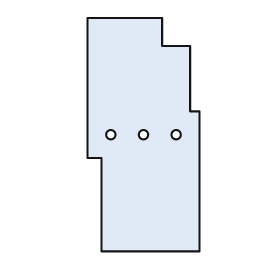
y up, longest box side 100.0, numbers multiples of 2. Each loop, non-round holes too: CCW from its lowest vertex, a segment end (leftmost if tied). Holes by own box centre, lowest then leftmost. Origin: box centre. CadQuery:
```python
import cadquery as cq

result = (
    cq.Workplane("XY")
    .moveTo(-18.0, -50.0)
    .lineTo(24.0, -50.0)
    .lineTo(24.0, 10.0)
    .lineTo(20.0, 10.0)
    .lineTo(20.0, 38.0)
    .lineTo(8.0, 38.0)
    .lineTo(8.0, 50.0)
    .lineTo(-24.0, 50.0)
    .lineTo(-24.0, -10.0)
    .lineTo(-18.0, -10.0)
    .close()
    .moveTo(-14.0, 0.0)
    .circle(2.0)
    .moveTo(0.0, 0.0)
    .circle(2.0)
    .moveTo(14.0, 0.0)
    .circle(2.0)
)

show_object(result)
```